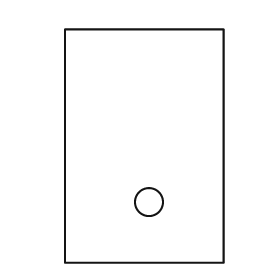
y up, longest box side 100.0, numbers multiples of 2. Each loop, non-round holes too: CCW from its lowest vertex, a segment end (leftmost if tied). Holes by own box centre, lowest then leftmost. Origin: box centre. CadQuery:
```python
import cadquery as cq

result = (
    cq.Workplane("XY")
    .moveTo(-34.0, -50.0)
    .lineTo(34.0, -50.0)
    .lineTo(34.0, 50.0)
    .lineTo(-34.0, 50.0)
    .close()
    .moveTo(2.0, -24.0)
    .circle(6.0)
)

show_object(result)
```